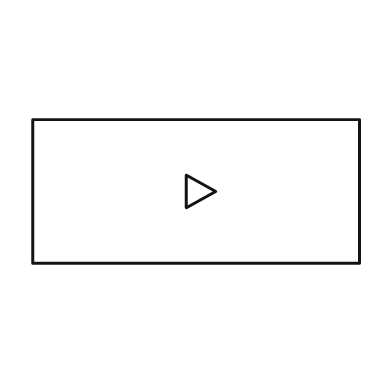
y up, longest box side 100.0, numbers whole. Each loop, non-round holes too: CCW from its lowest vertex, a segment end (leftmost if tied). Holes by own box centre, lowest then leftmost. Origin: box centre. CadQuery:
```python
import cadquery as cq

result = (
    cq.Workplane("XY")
    .moveTo(-50.0, -22.0)
    .lineTo(50.0, -22.0)
    .lineTo(50.0, 22.0)
    .lineTo(-50.0, 22.0)
    .close()
    .moveTo(-3.0, -5.0)
    .lineTo(6.0, 0.0)
    .lineTo(-3.0, 5.0)
    .close()
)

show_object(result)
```